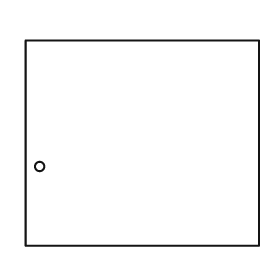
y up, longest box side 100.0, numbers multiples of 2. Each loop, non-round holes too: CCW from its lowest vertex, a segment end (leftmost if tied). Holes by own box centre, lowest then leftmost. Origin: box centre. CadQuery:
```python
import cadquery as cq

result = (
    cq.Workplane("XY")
    .moveTo(-50.0, -44.0)
    .lineTo(50.0, -44.0)
    .lineTo(50.0, 44.0)
    .lineTo(-50.0, 44.0)
    .close()
    .moveTo(-44.0, -10.0)
    .circle(2.0)
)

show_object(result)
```